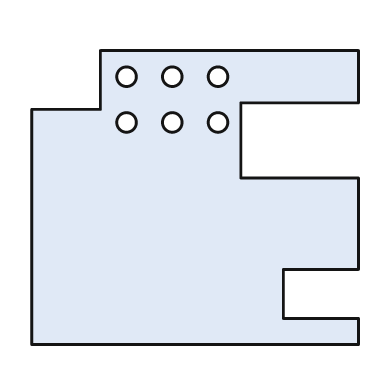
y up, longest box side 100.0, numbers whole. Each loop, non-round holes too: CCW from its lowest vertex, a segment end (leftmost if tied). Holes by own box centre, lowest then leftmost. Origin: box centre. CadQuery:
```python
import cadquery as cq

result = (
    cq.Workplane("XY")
    .moveTo(-50.0, -45.0)
    .lineTo(50.0, -45.0)
    .lineTo(50.0, -37.0)
    .lineTo(27.0, -37.0)
    .lineTo(27.0, -22.0)
    .lineTo(50.0, -22.0)
    .lineTo(50.0, 6.0)
    .lineTo(14.0, 6.0)
    .lineTo(14.0, 29.0)
    .lineTo(50.0, 29.0)
    .lineTo(50.0, 45.0)
    .lineTo(-29.0, 45.0)
    .lineTo(-29.0, 27.0)
    .lineTo(-50.0, 27.0)
    .close()
    .moveTo(-21.0, 23.0)
    .circle(3.0)
    .moveTo(-7.0, 23.0)
    .circle(3.0)
    .moveTo(7.0, 23.0)
    .circle(3.0)
    .moveTo(-21.0, 37.0)
    .circle(3.0)
    .moveTo(-7.0, 37.0)
    .circle(3.0)
    .moveTo(7.0, 37.0)
    .circle(3.0)
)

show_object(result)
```